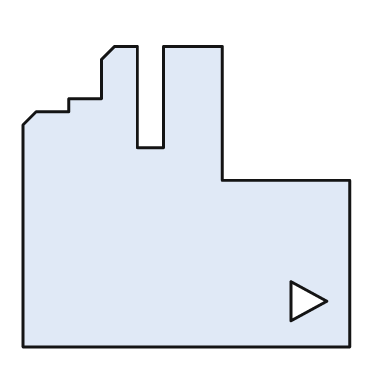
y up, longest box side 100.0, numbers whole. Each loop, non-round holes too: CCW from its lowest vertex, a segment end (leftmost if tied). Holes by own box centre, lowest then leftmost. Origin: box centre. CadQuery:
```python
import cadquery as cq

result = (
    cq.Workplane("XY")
    .moveTo(-50.0, -46.0)
    .lineTo(50.0, -46.0)
    .lineTo(50.0, 5.0)
    .lineTo(11.0, 5.0)
    .lineTo(11.0, 46.0)
    .lineTo(-7.0, 46.0)
    .lineTo(-7.0, 15.0)
    .lineTo(-15.0, 15.0)
    .lineTo(-15.0, 46.0)
    .lineTo(-22.0, 46.0)
    .lineTo(-26.0, 42.0)
    .lineTo(-26.0, 30.0)
    .lineTo(-36.0, 30.0)
    .lineTo(-36.0, 26.0)
    .lineTo(-46.0, 26.0)
    .lineTo(-50.0, 22.0)
    .close()
    .moveTo(32.0, -38.0)
    .lineTo(43.0, -32.0)
    .lineTo(32.0, -26.0)
    .close()
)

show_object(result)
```